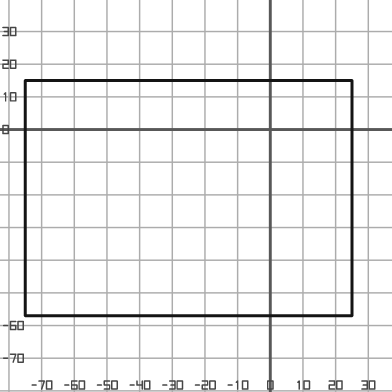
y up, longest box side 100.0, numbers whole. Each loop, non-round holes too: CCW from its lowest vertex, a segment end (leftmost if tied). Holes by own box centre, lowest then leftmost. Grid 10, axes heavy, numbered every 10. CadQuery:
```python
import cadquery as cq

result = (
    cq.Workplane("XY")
    .moveTo(-75.0, -57.0)
    .lineTo(25.0, -57.0)
    .lineTo(25.0, 15.0)
    .lineTo(-75.0, 15.0)
    .close()
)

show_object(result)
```